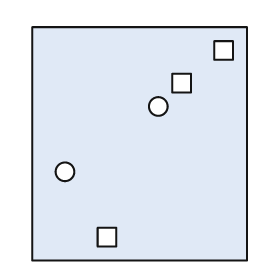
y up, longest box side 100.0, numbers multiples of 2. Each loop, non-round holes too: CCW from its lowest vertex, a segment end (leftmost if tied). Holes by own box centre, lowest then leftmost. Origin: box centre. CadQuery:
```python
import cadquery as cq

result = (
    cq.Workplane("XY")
    .moveTo(-46.0, -50.0)
    .lineTo(46.0, -50.0)
    .lineTo(46.0, 50.0)
    .lineTo(-46.0, 50.0)
    .close()
    .moveTo(-18.0, -44.0)
    .lineTo(-10.0, -44.0)
    .lineTo(-10.0, -36.0)
    .lineTo(-18.0, -36.0)
    .close()
    .moveTo(-32.0, -12.0)
    .circle(4.0)
    .moveTo(8.0, 16.0)
    .circle(4.0)
    .moveTo(14.0, 22.0)
    .lineTo(22.0, 22.0)
    .lineTo(22.0, 30.0)
    .lineTo(14.0, 30.0)
    .close()
    .moveTo(32.0, 36.0)
    .lineTo(40.0, 36.0)
    .lineTo(40.0, 44.0)
    .lineTo(32.0, 44.0)
    .close()
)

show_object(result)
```